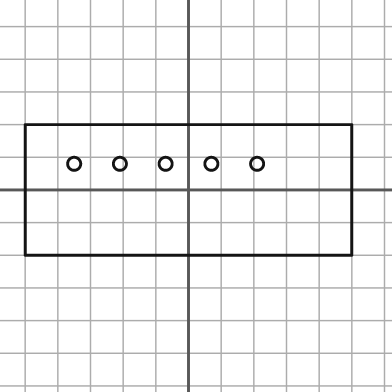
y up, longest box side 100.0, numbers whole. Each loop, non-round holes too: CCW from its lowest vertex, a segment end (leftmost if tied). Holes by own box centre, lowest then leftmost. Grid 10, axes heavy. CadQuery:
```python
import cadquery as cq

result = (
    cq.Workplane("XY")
    .moveTo(-50.0, -20.0)
    .lineTo(50.0, -20.0)
    .lineTo(50.0, 20.0)
    .lineTo(-50.0, 20.0)
    .close()
    .moveTo(-35.0, 8.0)
    .circle(2.0)
    .moveTo(-21.0, 8.0)
    .circle(2.0)
    .moveTo(-7.0, 8.0)
    .circle(2.0)
    .moveTo(7.0, 8.0)
    .circle(2.0)
    .moveTo(21.0, 8.0)
    .circle(2.0)
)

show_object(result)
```